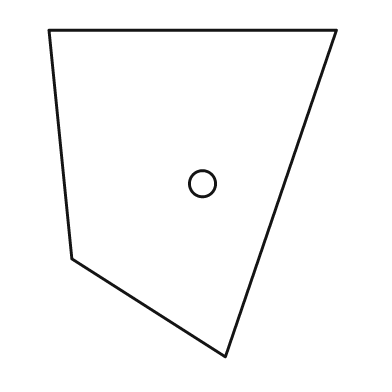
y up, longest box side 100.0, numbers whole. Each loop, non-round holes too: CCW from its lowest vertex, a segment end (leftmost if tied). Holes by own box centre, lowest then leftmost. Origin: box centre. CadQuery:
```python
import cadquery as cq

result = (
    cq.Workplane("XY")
    .moveTo(10.0, -50.0)
    .lineTo(44.0, 50.0)
    .lineTo(-44.0, 50.0)
    .lineTo(-37.0, -20.0)
    .close()
    .moveTo(3.0, 3.0)
    .circle(4.0)
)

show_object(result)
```